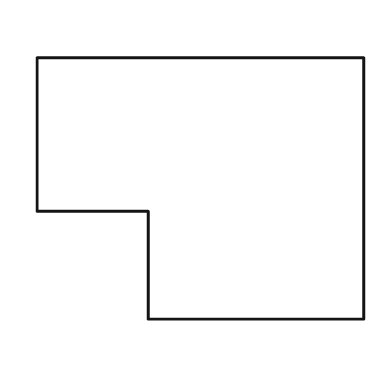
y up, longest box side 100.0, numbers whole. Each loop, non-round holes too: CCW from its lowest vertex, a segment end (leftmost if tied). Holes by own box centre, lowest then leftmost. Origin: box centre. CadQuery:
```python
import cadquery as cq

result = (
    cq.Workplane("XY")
    .moveTo(-16.0, -40.0)
    .lineTo(50.0, -40.0)
    .lineTo(50.0, 40.0)
    .lineTo(-50.0, 40.0)
    .lineTo(-50.0, -7.0)
    .lineTo(-16.0, -7.0)
    .close()
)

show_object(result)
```